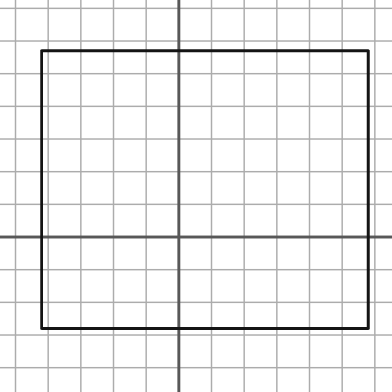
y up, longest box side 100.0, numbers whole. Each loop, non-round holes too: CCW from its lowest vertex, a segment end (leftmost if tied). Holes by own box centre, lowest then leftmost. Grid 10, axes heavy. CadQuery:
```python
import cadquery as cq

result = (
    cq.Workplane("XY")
    .moveTo(-42.0, -28.0)
    .lineTo(58.0, -28.0)
    .lineTo(58.0, 57.0)
    .lineTo(-42.0, 57.0)
    .close()
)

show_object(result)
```